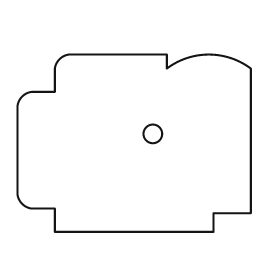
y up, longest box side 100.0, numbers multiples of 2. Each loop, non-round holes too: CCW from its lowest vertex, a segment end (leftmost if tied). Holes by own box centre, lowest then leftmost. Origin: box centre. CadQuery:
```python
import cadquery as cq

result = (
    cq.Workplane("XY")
    .moveTo(-34.0, -38.0)
    .lineTo(34.0, -38.0)
    .lineTo(34.0, -30.0)
    .lineTo(50.0, -30.0)
    .lineTo(50.0, 32.0)
    .threePointArc((32.0, 38.0), (14.0, 32.0))
    .lineTo(14.0, 38.0)
    .lineTo(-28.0, 38.0)
    .threePointArc((-32.0, 36.0), (-34.0, 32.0))
    .lineTo(-34.0, 22.0)
    .lineTo(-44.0, 22.0)
    .threePointArc((-48.0, 20.0), (-50.0, 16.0))
    .lineTo(-50.0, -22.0)
    .threePointArc((-48.0, -26.0), (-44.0, -28.0))
    .lineTo(-34.0, -28.0)
    .close()
    .moveTo(8.0, 4.0)
    .circle(4.0)
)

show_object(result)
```